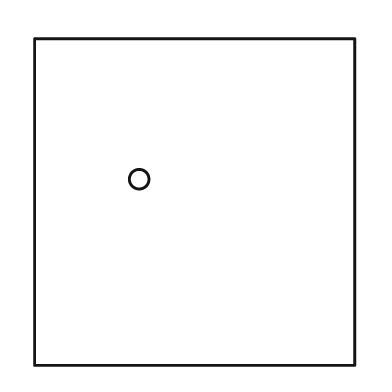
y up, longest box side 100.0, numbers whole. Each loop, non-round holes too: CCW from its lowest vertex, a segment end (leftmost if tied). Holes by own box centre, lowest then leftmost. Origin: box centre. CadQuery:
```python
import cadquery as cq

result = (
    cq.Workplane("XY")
    .moveTo(-49.0, -50.0)
    .lineTo(49.0, -50.0)
    .lineTo(49.0, 50.0)
    .lineTo(-49.0, 50.0)
    .close()
    .moveTo(-17.0, 7.0)
    .circle(3.0)
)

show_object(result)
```